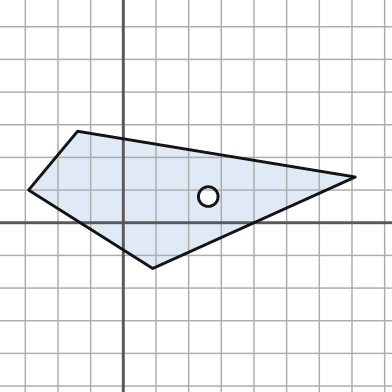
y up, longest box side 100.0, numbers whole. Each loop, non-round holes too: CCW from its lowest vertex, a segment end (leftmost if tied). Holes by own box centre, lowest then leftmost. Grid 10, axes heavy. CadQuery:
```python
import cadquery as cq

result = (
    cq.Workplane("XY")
    .moveTo(9.0, -14.0)
    .lineTo(71.0, 14.0)
    .lineTo(-14.0, 28.0)
    .lineTo(-29.0, 10.0)
    .close()
    .moveTo(26.0, 8.0)
    .circle(3.0)
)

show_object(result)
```